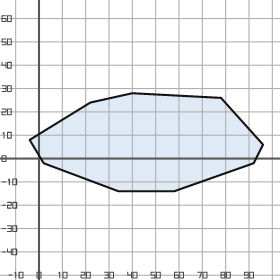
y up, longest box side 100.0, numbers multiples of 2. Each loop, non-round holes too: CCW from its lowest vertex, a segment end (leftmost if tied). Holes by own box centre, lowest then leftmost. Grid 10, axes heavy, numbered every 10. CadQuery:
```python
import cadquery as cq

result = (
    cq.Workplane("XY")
    .moveTo(34.0, -14.0)
    .lineTo(58.0, -14.0)
    .lineTo(92.0, -2.0)
    .lineTo(96.0, 6.0)
    .lineTo(78.0, 26.0)
    .lineTo(40.0, 28.0)
    .lineTo(22.0, 24.0)
    .lineTo(-4.0, 8.0)
    .lineTo(2.0, -2.0)
    .close()
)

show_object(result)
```